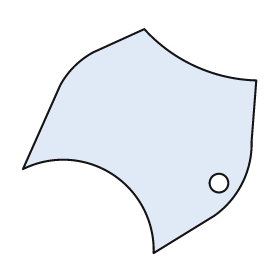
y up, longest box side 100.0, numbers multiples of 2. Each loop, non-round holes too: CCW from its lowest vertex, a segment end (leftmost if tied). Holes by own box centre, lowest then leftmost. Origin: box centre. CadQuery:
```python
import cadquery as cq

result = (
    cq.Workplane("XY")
    .moveTo(6.0, -48.0)
    .lineTo(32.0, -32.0)
    .threePointArc((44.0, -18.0), (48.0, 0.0))
    .lineTo(50.0, 26.0)
    .threePointArc((24.0, 32.0), (2.0, 48.0))
    .lineTo(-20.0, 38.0)
    .threePointArc((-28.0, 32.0), (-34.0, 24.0))
    .lineTo(-50.0, -12.0)
    .threePointArc((-12.0, -14.0), (6.0, -48.0))
    .close()
    .moveTo(34.0, -18.0)
    .circle(4.0)
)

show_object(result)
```